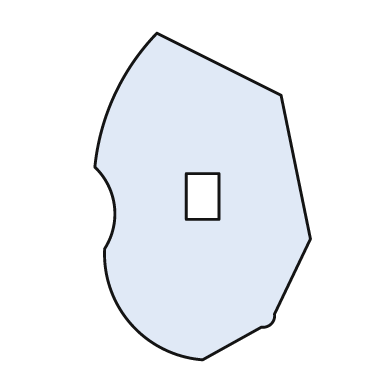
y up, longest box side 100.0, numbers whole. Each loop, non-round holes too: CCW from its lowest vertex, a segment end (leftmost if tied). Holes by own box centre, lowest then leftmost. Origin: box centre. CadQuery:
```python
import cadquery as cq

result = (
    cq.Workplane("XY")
    .moveTo(0.0, -50.0)
    .lineTo(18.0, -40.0)
    .threePointArc((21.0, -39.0), (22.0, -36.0))
    .lineTo(33.0, -13.0)
    .lineTo(24.0, 31.0)
    .lineTo(-14.0, 50.0)
    .threePointArc((-27.0, 31.0), (-33.0, 9.0))
    .threePointArc((-27.0, -3.0), (-30.0, -16.0))
    .threePointArc((-22.0, -39.0), (0.0, -50.0))
    .close()
    .moveTo(-5.0, -7.0)
    .lineTo(5.0, -7.0)
    .lineTo(5.0, 7.0)
    .lineTo(-5.0, 7.0)
    .close()
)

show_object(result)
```